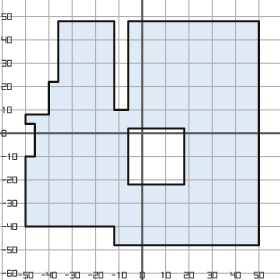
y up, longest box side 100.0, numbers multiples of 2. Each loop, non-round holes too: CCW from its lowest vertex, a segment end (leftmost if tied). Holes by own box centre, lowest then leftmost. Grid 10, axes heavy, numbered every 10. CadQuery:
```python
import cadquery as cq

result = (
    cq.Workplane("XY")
    .moveTo(-12.0, -48.0)
    .lineTo(50.0, -48.0)
    .lineTo(50.0, 48.0)
    .lineTo(-6.0, 48.0)
    .lineTo(-6.0, 10.0)
    .lineTo(-12.0, 10.0)
    .lineTo(-12.0, 48.0)
    .lineTo(-36.0, 48.0)
    .lineTo(-36.0, 22.0)
    .lineTo(-40.0, 22.0)
    .lineTo(-40.0, 8.0)
    .lineTo(-50.0, 8.0)
    .lineTo(-50.0, 4.0)
    .lineTo(-46.0, 4.0)
    .lineTo(-46.0, -10.0)
    .lineTo(-50.0, -10.0)
    .lineTo(-50.0, -40.0)
    .lineTo(-12.0, -40.0)
    .close()
    .moveTo(-6.0, -22.0)
    .lineTo(18.0, -22.0)
    .lineTo(18.0, 2.0)
    .lineTo(-6.0, 2.0)
    .close()
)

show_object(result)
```